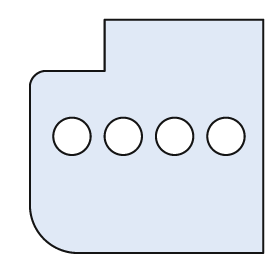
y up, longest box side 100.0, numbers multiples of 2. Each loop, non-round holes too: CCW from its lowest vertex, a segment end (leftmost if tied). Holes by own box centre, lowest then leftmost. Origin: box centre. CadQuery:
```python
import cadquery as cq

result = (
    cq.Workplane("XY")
    .moveTo(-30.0, -50.0)
    .lineTo(50.0, -50.0)
    .lineTo(50.0, 50.0)
    .lineTo(-18.0, 50.0)
    .lineTo(-18.0, 28.0)
    .lineTo(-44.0, 28.0)
    .threePointArc((-48.0, 26.0), (-50.0, 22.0))
    .lineTo(-50.0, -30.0)
    .threePointArc((-44.0, -44.0), (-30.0, -50.0))
    .close()
    .moveTo(-32.0, 0.0)
    .circle(8.0)
    .moveTo(-10.0, 0.0)
    .circle(8.0)
    .moveTo(12.0, 0.0)
    .circle(8.0)
    .moveTo(34.0, 0.0)
    .circle(8.0)
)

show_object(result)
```